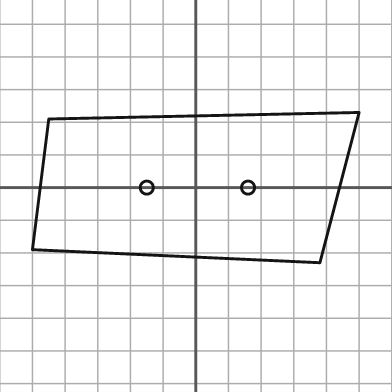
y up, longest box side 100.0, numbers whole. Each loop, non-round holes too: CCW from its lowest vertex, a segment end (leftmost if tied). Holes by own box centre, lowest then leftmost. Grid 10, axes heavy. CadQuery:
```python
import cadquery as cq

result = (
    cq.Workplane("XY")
    .moveTo(38.0, -23.0)
    .lineTo(50.0, 23.0)
    .lineTo(-45.0, 21.0)
    .lineTo(-50.0, -19.0)
    .close()
    .moveTo(-15.0, 0.0)
    .circle(2.0)
    .moveTo(16.0, 0.0)
    .circle(2.0)
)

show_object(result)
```